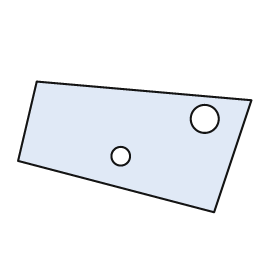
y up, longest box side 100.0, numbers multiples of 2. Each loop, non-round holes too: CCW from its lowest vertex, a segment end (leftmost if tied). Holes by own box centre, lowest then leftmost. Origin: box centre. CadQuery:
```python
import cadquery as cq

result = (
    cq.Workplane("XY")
    .moveTo(34.0, -28.0)
    .lineTo(50.0, 20.0)
    .lineTo(-42.0, 28.0)
    .lineTo(-50.0, -6.0)
    .close()
    .moveTo(-6.0, -4.0)
    .circle(4.0)
    .moveTo(30.0, 12.0)
    .circle(6.0)
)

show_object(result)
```